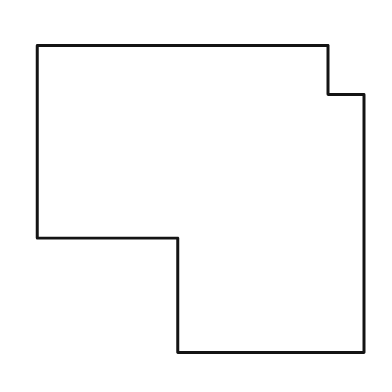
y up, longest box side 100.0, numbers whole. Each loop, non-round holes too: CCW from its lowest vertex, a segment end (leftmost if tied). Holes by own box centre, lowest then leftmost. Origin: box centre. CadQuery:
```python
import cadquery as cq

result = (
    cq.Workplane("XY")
    .moveTo(-7.0, -47.0)
    .lineTo(50.0, -47.0)
    .lineTo(50.0, 32.0)
    .lineTo(39.0, 32.0)
    .lineTo(39.0, 47.0)
    .lineTo(-50.0, 47.0)
    .lineTo(-50.0, -12.0)
    .lineTo(-7.0, -12.0)
    .close()
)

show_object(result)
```